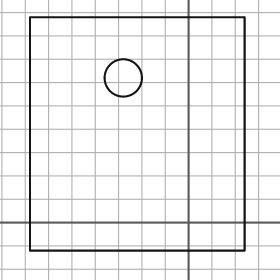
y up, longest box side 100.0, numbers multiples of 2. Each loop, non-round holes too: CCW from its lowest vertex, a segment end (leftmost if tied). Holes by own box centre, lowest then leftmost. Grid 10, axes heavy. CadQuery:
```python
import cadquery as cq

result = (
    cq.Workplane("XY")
    .moveTo(-68.0, -12.0)
    .lineTo(24.0, -12.0)
    .lineTo(24.0, 88.0)
    .lineTo(-68.0, 88.0)
    .close()
    .moveTo(-28.0, 62.0)
    .circle(8.0)
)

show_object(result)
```